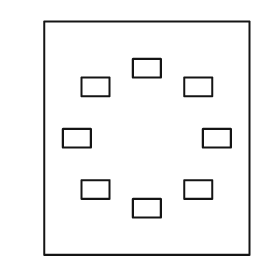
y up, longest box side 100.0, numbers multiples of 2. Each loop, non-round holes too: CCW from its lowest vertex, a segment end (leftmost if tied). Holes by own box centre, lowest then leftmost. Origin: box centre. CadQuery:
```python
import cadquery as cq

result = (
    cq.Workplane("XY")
    .moveTo(-44.0, -50.0)
    .lineTo(44.0, -50.0)
    .lineTo(44.0, 50.0)
    .lineTo(-44.0, 50.0)
    .close()
    .moveTo(-6.0, -34.0)
    .lineTo(6.0, -34.0)
    .lineTo(6.0, -26.0)
    .lineTo(-6.0, -26.0)
    .close()
    .moveTo(-28.0, -26.0)
    .lineTo(-16.0, -26.0)
    .lineTo(-16.0, -18.0)
    .lineTo(-28.0, -18.0)
    .close()
    .moveTo(16.0, -26.0)
    .lineTo(28.0, -26.0)
    .lineTo(28.0, -18.0)
    .lineTo(16.0, -18.0)
    .close()
    .moveTo(-36.0, -4.0)
    .lineTo(-24.0, -4.0)
    .lineTo(-24.0, 4.0)
    .lineTo(-36.0, 4.0)
    .close()
    .moveTo(24.0, -4.0)
    .lineTo(36.0, -4.0)
    .lineTo(36.0, 4.0)
    .lineTo(24.0, 4.0)
    .close()
    .moveTo(-28.0, 18.0)
    .lineTo(-16.0, 18.0)
    .lineTo(-16.0, 26.0)
    .lineTo(-28.0, 26.0)
    .close()
    .moveTo(16.0, 18.0)
    .lineTo(28.0, 18.0)
    .lineTo(28.0, 26.0)
    .lineTo(16.0, 26.0)
    .close()
    .moveTo(-6.0, 26.0)
    .lineTo(6.0, 26.0)
    .lineTo(6.0, 34.0)
    .lineTo(-6.0, 34.0)
    .close()
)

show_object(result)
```